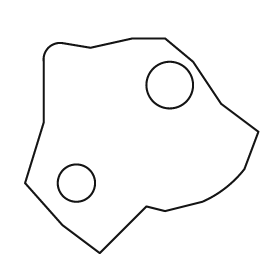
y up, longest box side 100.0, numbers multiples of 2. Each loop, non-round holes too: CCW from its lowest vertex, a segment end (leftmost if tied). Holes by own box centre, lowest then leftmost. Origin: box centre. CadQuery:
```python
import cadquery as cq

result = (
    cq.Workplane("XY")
    .moveTo(-18.0, -46.0)
    .lineTo(2.0, -26.0)
    .lineTo(10.0, -28.0)
    .lineTo(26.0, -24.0)
    .threePointArc((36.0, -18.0), (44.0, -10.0))
    .lineTo(50.0, 6.0)
    .lineTo(34.0, 18.0)
    .lineTo(22.0, 36.0)
    .lineTo(10.0, 46.0)
    .lineTo(-4.0, 46.0)
    .lineTo(-22.0, 42.0)
    .lineTo(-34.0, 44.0)
    .threePointArc((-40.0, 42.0), (-42.0, 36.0))
    .lineTo(-42.0, 10.0)
    .lineTo(-50.0, -16.0)
    .lineTo(-34.0, -34.0)
    .close()
    .moveTo(-28.0, -16.0)
    .circle(8.0)
    .moveTo(12.0, 26.0)
    .circle(10.0)
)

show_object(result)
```